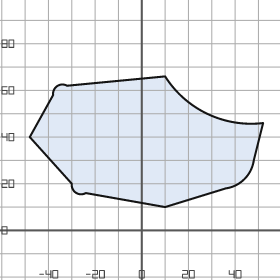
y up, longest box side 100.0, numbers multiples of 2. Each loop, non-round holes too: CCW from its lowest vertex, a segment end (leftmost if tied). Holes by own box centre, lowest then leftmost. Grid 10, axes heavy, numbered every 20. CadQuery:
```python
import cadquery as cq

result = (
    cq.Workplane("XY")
    .moveTo(10.0, 10.0)
    .lineTo(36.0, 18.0)
    .threePointArc((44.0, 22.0), (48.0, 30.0))
    .lineTo(52.0, 46.0)
    .threePointArc((28.0, 50.0), (10.0, 66.0))
    .lineTo(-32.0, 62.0)
    .threePointArc((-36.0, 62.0), (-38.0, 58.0))
    .lineTo(-48.0, 40.0)
    .lineTo(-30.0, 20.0)
    .threePointArc((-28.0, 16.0), (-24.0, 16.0))
    .close()
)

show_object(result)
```